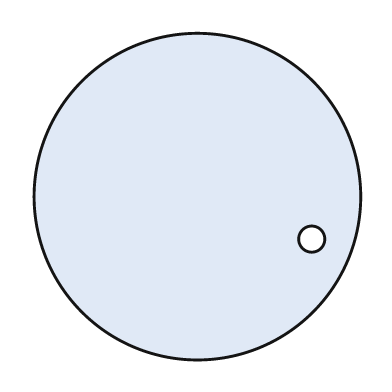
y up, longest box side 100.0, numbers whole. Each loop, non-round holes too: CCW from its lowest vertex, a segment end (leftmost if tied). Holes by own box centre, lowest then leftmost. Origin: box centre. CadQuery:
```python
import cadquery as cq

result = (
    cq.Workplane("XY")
    .moveTo(0.0, 0.0)
    .circle(50.0)
    .moveTo(35.0, -13.0)
    .circle(4.0)
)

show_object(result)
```